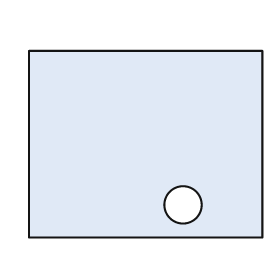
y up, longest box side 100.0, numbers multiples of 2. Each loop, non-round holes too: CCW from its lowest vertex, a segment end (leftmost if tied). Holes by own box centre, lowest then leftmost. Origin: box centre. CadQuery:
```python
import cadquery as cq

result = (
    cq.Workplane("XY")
    .moveTo(-50.0, -40.0)
    .lineTo(50.0, -40.0)
    .lineTo(50.0, 40.0)
    .lineTo(-50.0, 40.0)
    .close()
    .moveTo(16.0, -26.0)
    .circle(8.0)
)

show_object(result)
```